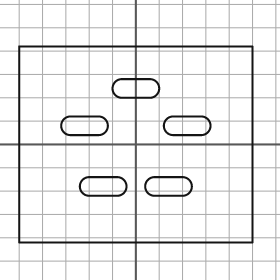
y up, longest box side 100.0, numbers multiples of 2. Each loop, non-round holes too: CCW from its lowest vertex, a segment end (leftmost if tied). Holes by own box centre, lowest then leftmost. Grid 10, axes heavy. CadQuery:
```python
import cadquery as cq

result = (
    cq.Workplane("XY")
    .moveTo(-50.0, -42.0)
    .lineTo(50.0, -42.0)
    .lineTo(50.0, 42.0)
    .lineTo(-50.0, 42.0)
    .close()
    .moveTo(-20.0, -22.0)
    .lineTo(-8.0, -22.0)
    .threePointArc((-4.0, -18.0), (-8.0, -14.0))
    .lineTo(-20.0, -14.0)
    .threePointArc((-24.0, -18.0), (-20.0, -22.0))
    .close()
    .moveTo(8.0, -22.0)
    .lineTo(20.0, -22.0)
    .threePointArc((24.0, -18.0), (20.0, -14.0))
    .lineTo(8.0, -14.0)
    .threePointArc((4.0, -18.0), (8.0, -22.0))
    .close()
    .moveTo(-28.0, 4.0)
    .lineTo(-16.0, 4.0)
    .threePointArc((-12.0, 8.0), (-16.0, 12.0))
    .lineTo(-28.0, 12.0)
    .threePointArc((-32.0, 8.0), (-28.0, 4.0))
    .close()
    .moveTo(16.0, 4.0)
    .lineTo(28.0, 4.0)
    .threePointArc((32.0, 8.0), (28.0, 12.0))
    .lineTo(16.0, 12.0)
    .threePointArc((12.0, 8.0), (16.0, 4.0))
    .close()
    .moveTo(-6.0, 20.0)
    .lineTo(6.0, 20.0)
    .threePointArc((10.0, 24.0), (6.0, 28.0))
    .lineTo(-6.0, 28.0)
    .threePointArc((-10.0, 24.0), (-6.0, 20.0))
    .close()
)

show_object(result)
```